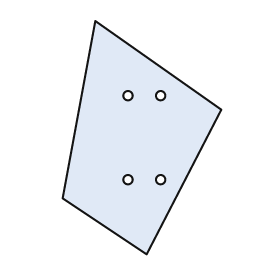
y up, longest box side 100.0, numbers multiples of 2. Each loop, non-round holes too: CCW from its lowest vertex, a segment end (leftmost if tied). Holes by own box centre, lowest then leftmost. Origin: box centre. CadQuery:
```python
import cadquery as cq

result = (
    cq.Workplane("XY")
    .moveTo(2.0, -50.0)
    .lineTo(34.0, 12.0)
    .lineTo(-20.0, 50.0)
    .lineTo(-34.0, -26.0)
    .close()
    .moveTo(-6.0, -18.0)
    .circle(2.0)
    .moveTo(8.0, -18.0)
    .circle(2.0)
    .moveTo(-6.0, 18.0)
    .circle(2.0)
    .moveTo(8.0, 18.0)
    .circle(2.0)
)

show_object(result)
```